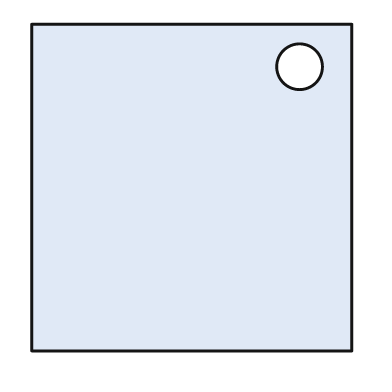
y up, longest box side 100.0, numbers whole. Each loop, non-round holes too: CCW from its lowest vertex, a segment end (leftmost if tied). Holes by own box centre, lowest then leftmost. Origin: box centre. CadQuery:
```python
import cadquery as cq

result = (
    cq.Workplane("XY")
    .moveTo(-49.0, -50.0)
    .lineTo(49.0, -50.0)
    .lineTo(49.0, 50.0)
    .lineTo(-49.0, 50.0)
    .close()
    .moveTo(33.0, 37.0)
    .circle(7.0)
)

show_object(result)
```